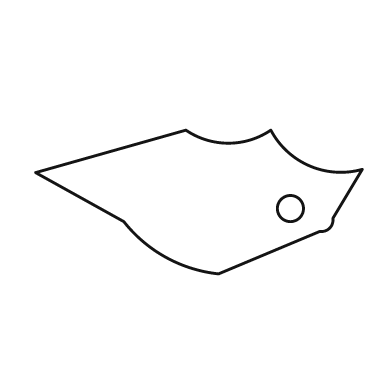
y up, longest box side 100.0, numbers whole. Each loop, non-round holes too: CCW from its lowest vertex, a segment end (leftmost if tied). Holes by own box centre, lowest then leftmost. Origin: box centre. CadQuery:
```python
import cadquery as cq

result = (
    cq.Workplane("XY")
    .moveTo(6.0, -22.0)
    .lineTo(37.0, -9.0)
    .threePointArc((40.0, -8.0), (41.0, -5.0))
    .lineTo(50.0, 10.0)
    .threePointArc((34.0, 11.0), (22.0, 22.0))
    .threePointArc((9.0, 18.0), (-4.0, 22.0))
    .lineTo(-50.0, 9.0)
    .lineTo(-23.0, -6.0)
    .threePointArc((-10.0, -17.0), (6.0, -22.0))
    .close()
    .moveTo(28.0, -2.0)
    .circle(4.0)
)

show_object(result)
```